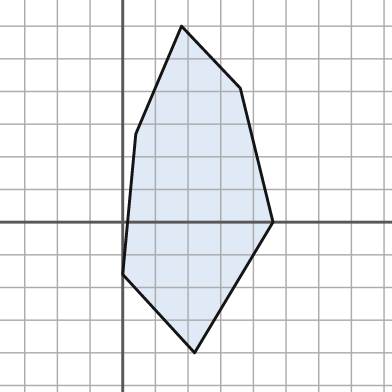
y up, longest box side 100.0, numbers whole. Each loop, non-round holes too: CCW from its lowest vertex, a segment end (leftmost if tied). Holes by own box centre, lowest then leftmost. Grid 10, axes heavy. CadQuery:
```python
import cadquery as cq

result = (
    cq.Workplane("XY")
    .moveTo(22.0, -40.0)
    .lineTo(46.0, 0.0)
    .lineTo(36.0, 41.0)
    .lineTo(18.0, 60.0)
    .lineTo(4.0, 27.0)
    .lineTo(0.0, -16.0)
    .close()
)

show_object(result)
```